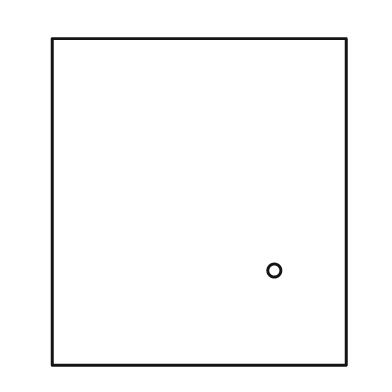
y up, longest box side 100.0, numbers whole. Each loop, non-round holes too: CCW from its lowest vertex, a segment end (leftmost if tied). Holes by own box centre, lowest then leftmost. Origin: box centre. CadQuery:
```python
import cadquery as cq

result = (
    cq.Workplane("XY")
    .moveTo(-45.0, -50.0)
    .lineTo(45.0, -50.0)
    .lineTo(45.0, 50.0)
    .lineTo(-45.0, 50.0)
    .close()
    .moveTo(23.0, -21.0)
    .circle(2.0)
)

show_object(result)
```